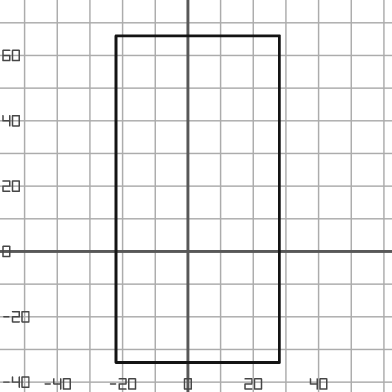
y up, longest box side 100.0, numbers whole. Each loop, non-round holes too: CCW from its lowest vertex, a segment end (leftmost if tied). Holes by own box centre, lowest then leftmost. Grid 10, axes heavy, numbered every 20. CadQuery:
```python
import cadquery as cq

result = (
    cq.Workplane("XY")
    .moveTo(-22.0, -34.0)
    .lineTo(28.0, -34.0)
    .lineTo(28.0, 66.0)
    .lineTo(-22.0, 66.0)
    .close()
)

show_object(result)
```